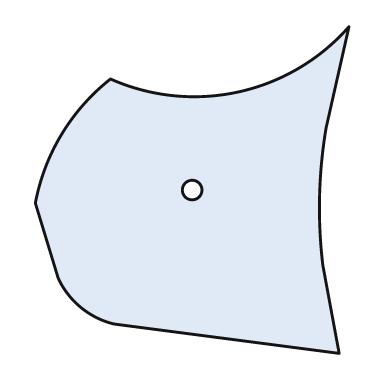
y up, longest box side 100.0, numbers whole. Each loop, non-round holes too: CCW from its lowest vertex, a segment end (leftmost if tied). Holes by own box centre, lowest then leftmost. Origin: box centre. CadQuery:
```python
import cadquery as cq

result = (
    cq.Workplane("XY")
    .moveTo(45.0, -50.0)
    .lineTo(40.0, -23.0)
    .threePointArc((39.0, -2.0), (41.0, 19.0))
    .lineTo(48.0, 50.0)
    .threePointArc((14.0, 30.0), (-25.0, 34.0))
    .threePointArc((-40.0, 17.0), (-48.0, -4.0))
    .lineTo(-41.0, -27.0)
    .threePointArc((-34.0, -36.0), (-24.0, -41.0))
    .close()
    .moveTo(0.0, 0.0)
    .circle(3.0)
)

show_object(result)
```